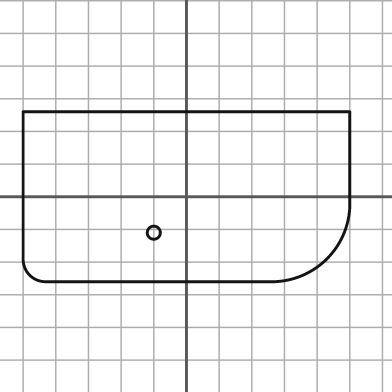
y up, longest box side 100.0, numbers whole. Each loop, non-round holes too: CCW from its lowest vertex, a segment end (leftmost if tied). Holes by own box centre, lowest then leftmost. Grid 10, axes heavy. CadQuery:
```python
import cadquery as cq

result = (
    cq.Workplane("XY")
    .moveTo(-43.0, -26.0)
    .lineTo(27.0, -26.0)
    .threePointArc((43.0, -19.0), (50.0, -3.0))
    .lineTo(50.0, 26.0)
    .lineTo(-50.0, 26.0)
    .lineTo(-50.0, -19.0)
    .threePointArc((-48.0, -24.0), (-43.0, -26.0))
    .close()
    .moveTo(-10.0, -11.0)
    .circle(2.0)
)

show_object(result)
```